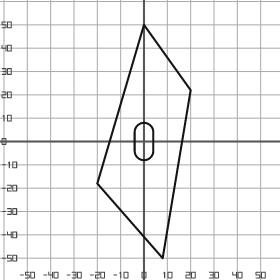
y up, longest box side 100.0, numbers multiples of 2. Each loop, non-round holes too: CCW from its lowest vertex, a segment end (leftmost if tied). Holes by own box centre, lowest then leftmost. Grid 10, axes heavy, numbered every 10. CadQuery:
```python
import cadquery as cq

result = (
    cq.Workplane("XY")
    .moveTo(8.0, -50.0)
    .lineTo(20.0, 22.0)
    .lineTo(0.0, 50.0)
    .lineTo(-20.0, -18.0)
    .close()
    .moveTo(-4.0, -4.0)
    .threePointArc((0.0, -8.0), (4.0, -4.0))
    .lineTo(4.0, 4.0)
    .threePointArc((0.0, 8.0), (-4.0, 4.0))
    .close()
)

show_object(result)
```